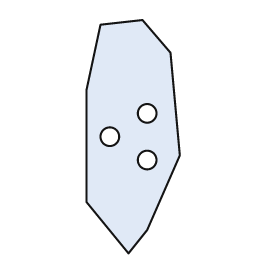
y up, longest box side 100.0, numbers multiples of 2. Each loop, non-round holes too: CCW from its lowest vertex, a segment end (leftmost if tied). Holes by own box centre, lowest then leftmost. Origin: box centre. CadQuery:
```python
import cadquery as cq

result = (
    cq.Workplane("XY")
    .moveTo(-2.0, -50.0)
    .lineTo(6.0, -40.0)
    .lineTo(20.0, -8.0)
    .lineTo(16.0, 36.0)
    .lineTo(4.0, 50.0)
    .lineTo(-14.0, 48.0)
    .lineTo(-20.0, 20.0)
    .lineTo(-20.0, -28.0)
    .close()
    .moveTo(6.0, -10.0)
    .circle(4.0)
    .moveTo(-10.0, 0.0)
    .circle(4.0)
    .moveTo(6.0, 10.0)
    .circle(4.0)
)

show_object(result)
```